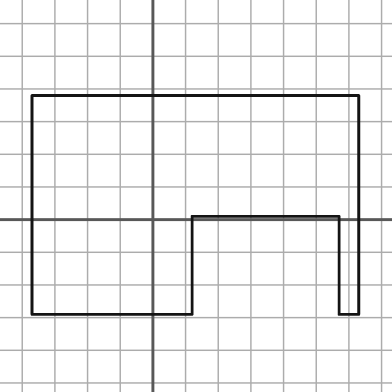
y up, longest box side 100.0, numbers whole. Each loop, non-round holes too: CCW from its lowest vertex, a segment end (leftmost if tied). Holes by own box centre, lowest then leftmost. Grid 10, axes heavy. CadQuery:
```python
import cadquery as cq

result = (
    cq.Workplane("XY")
    .moveTo(-37.0, -29.0)
    .lineTo(12.0, -29.0)
    .lineTo(12.0, 1.0)
    .lineTo(57.0, 1.0)
    .lineTo(57.0, -29.0)
    .lineTo(63.0, -29.0)
    .lineTo(63.0, 38.0)
    .lineTo(-37.0, 38.0)
    .close()
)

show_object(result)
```